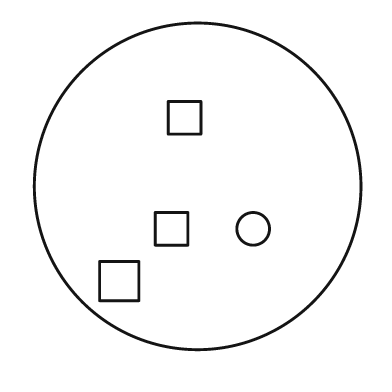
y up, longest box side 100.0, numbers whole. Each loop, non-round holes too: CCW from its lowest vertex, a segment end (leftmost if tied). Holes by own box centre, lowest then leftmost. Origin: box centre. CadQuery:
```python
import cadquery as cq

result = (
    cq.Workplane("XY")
    .moveTo(0.0, 0.0)
    .circle(50.0)
    .moveTo(-30.0, -35.0)
    .lineTo(-18.0, -35.0)
    .lineTo(-18.0, -23.0)
    .lineTo(-30.0, -23.0)
    .close()
    .moveTo(-13.0, -18.0)
    .lineTo(-3.0, -18.0)
    .lineTo(-3.0, -8.0)
    .lineTo(-13.0, -8.0)
    .close()
    .moveTo(17.0, -13.0)
    .circle(5.0)
    .moveTo(-9.0, 16.0)
    .lineTo(1.0, 16.0)
    .lineTo(1.0, 26.0)
    .lineTo(-9.0, 26.0)
    .close()
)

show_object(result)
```